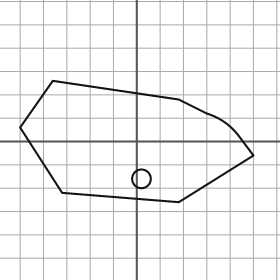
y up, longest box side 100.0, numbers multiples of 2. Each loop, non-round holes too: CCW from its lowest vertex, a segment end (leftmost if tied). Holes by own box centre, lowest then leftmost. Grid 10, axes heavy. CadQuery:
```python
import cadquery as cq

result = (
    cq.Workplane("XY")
    .moveTo(18.0, -26.0)
    .lineTo(50.0, -6.0)
    .lineTo(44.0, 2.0)
    .threePointArc((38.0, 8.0), (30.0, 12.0))
    .lineTo(18.0, 18.0)
    .lineTo(-36.0, 26.0)
    .lineTo(-50.0, 6.0)
    .lineTo(-32.0, -22.0)
    .close()
    .moveTo(2.0, -16.0)
    .circle(4.0)
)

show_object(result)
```